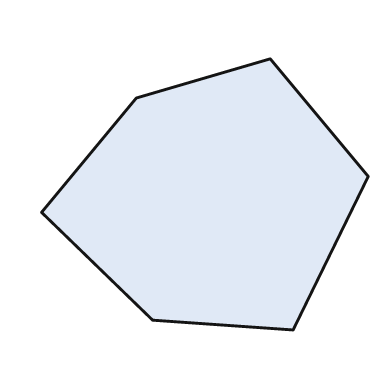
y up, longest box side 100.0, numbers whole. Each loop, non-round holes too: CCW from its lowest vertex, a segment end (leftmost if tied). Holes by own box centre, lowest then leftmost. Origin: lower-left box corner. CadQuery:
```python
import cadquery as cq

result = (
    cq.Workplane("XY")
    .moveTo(77.0, 0.0)
    .lineTo(100.0, 47.0)
    .lineTo(70.0, 83.0)
    .lineTo(29.0, 71.0)
    .lineTo(0.0, 36.0)
    .lineTo(34.0, 3.0)
    .close()
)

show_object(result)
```